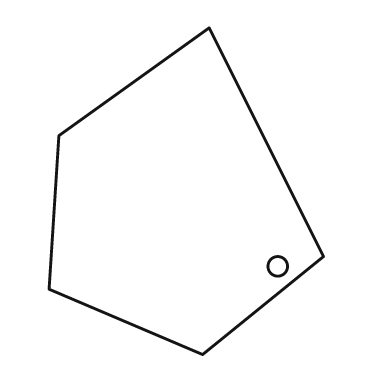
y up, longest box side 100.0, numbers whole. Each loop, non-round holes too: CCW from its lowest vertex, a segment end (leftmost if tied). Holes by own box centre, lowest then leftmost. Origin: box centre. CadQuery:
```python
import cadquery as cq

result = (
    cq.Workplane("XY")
    .moveTo(5.0, -50.0)
    .lineTo(42.0, -20.0)
    .lineTo(7.0, 50.0)
    .lineTo(-39.0, 17.0)
    .lineTo(-42.0, -30.0)
    .close()
    .moveTo(28.0, -23.0)
    .circle(3.0)
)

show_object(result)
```